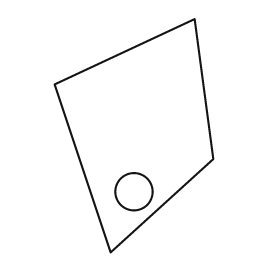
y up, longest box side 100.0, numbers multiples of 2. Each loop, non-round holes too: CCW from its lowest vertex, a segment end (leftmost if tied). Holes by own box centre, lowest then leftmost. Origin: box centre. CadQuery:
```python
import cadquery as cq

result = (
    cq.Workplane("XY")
    .moveTo(-10.0, -50.0)
    .lineTo(34.0, -10.0)
    .lineTo(26.0, 50.0)
    .lineTo(-34.0, 22.0)
    .close()
    .moveTo(0.0, -24.0)
    .circle(8.0)
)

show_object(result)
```